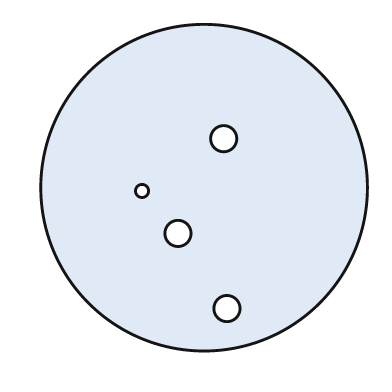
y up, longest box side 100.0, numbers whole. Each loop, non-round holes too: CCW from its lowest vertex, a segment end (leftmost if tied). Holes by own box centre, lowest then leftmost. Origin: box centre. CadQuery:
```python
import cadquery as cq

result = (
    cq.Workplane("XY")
    .moveTo(0.0, 0.0)
    .circle(50.0)
    .moveTo(7.0, -37.0)
    .circle(4.0)
    .moveTo(-8.0, -14.0)
    .circle(4.0)
    .moveTo(-19.0, -1.0)
    .circle(2.0)
    .moveTo(6.0, 15.0)
    .circle(4.0)
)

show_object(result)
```